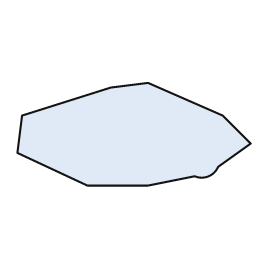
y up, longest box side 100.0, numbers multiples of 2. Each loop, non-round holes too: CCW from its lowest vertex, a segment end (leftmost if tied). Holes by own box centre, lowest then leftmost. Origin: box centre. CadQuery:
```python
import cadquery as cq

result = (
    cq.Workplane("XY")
    .moveTo(-20.0, -22.0)
    .lineTo(6.0, -22.0)
    .lineTo(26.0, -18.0)
    .threePointArc((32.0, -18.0), (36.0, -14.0))
    .lineTo(50.0, -4.0)
    .lineTo(38.0, 8.0)
    .lineTo(6.0, 22.0)
    .lineTo(-10.0, 20.0)
    .lineTo(-48.0, 8.0)
    .lineTo(-50.0, -8.0)
    .close()
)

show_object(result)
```